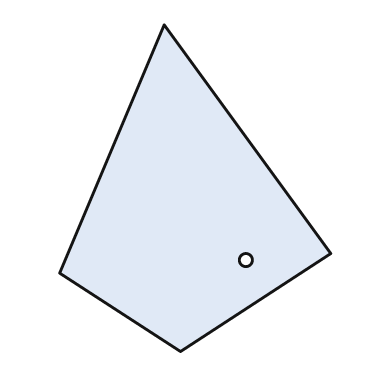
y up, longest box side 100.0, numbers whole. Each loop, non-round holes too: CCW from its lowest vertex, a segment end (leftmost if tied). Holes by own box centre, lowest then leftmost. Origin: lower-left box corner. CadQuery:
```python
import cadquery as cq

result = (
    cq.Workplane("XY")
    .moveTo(37.0, 0.0)
    .lineTo(83.0, 30.0)
    .lineTo(32.0, 100.0)
    .lineTo(0.0, 24.0)
    .close()
    .moveTo(57.0, 28.0)
    .circle(2.0)
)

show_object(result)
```